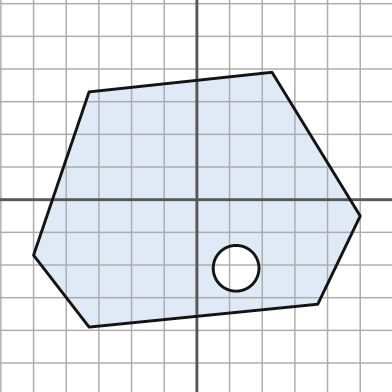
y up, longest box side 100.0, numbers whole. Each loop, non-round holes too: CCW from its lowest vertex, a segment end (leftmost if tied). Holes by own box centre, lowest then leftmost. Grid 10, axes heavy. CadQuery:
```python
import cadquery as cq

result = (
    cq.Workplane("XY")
    .moveTo(-33.0, -39.0)
    .lineTo(37.0, -32.0)
    .lineTo(50.0, -5.0)
    .lineTo(23.0, 39.0)
    .lineTo(-33.0, 33.0)
    .lineTo(-50.0, -17.0)
    .close()
    .moveTo(12.0, -21.0)
    .circle(7.0)
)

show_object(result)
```